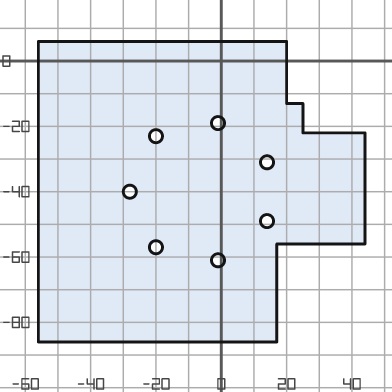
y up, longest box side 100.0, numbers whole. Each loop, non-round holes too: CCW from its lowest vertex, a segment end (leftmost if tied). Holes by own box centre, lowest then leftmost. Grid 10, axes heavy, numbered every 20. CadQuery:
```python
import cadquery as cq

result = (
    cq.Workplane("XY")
    .moveTo(-56.0, -86.0)
    .lineTo(17.0, -86.0)
    .lineTo(17.0, -56.0)
    .lineTo(44.0, -56.0)
    .lineTo(44.0, -22.0)
    .lineTo(25.0, -22.0)
    .lineTo(25.0, -13.0)
    .lineTo(20.0, -13.0)
    .lineTo(20.0, 6.0)
    .lineTo(-56.0, 6.0)
    .close()
    .moveTo(-1.0, -61.0)
    .circle(2.0)
    .moveTo(-20.0, -57.0)
    .circle(2.0)
    .moveTo(14.0, -49.0)
    .circle(2.0)
    .moveTo(-28.0, -40.0)
    .circle(2.0)
    .moveTo(14.0, -31.0)
    .circle(2.0)
    .moveTo(-20.0, -23.0)
    .circle(2.0)
    .moveTo(-1.0, -19.0)
    .circle(2.0)
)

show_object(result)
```